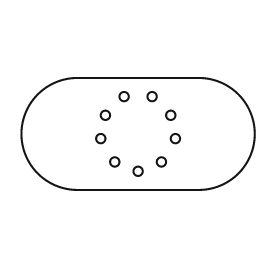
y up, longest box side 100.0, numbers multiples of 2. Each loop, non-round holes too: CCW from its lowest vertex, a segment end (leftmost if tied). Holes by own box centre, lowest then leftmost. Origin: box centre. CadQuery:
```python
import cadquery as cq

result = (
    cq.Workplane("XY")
    .moveTo(-26.0, -24.0)
    .lineTo(26.0, -24.0)
    .threePointArc((50.0, 0.0), (26.0, 24.0))
    .lineTo(-26.0, 24.0)
    .threePointArc((-50.0, 0.0), (-26.0, -24.0))
    .close()
    .moveTo(0.0, -16.0)
    .circle(2.0)
    .moveTo(-10.0, -12.0)
    .circle(2.0)
    .moveTo(10.0, -12.0)
    .circle(2.0)
    .moveTo(-16.0, -2.0)
    .circle(2.0)
    .moveTo(16.0, -2.0)
    .circle(2.0)
    .moveTo(-14.0, 8.0)
    .circle(2.0)
    .moveTo(14.0, 8.0)
    .circle(2.0)
    .moveTo(-6.0, 16.0)
    .circle(2.0)
    .moveTo(6.0, 16.0)
    .circle(2.0)
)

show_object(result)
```